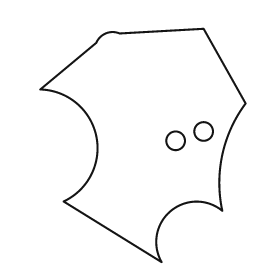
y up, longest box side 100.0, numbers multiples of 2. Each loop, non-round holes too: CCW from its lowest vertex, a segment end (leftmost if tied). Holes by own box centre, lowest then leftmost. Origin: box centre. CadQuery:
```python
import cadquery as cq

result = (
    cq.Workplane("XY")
    .moveTo(8.0, -50.0)
    .threePointArc((12.0, -28.0), (34.0, -28.0))
    .threePointArc((34.0, -4.0), (44.0, 18.0))
    .lineTo(26.0, 50.0)
    .lineTo(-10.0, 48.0)
    .threePointArc((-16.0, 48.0), (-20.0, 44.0))
    .lineTo(-44.0, 24.0)
    .threePointArc((-20.0, 4.0), (-34.0, -24.0))
    .close()
    .moveTo(14.0, 2.0)
    .circle(4.0)
    .moveTo(26.0, 6.0)
    .circle(4.0)
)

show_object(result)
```